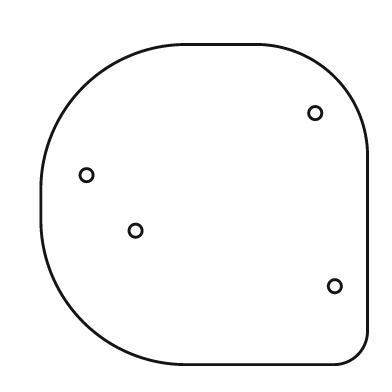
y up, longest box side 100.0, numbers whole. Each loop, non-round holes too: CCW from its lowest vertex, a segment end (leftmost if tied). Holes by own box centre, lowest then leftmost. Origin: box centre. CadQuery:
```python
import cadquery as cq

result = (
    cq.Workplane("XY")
    .moveTo(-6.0, -49.0)
    .lineTo(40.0, -49.0)
    .threePointArc((47.0, -46.0), (50.0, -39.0))
    .lineTo(50.0, 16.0)
    .threePointArc((40.0, 39.0), (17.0, 49.0))
    .lineTo(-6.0, 49.0)
    .threePointArc((-37.0, 36.0), (-50.0, 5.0))
    .lineTo(-50.0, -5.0)
    .threePointArc((-37.0, -36.0), (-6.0, -49.0))
    .close()
    .moveTo(40.0, -25.0)
    .circle(2.0)
    .moveTo(-21.0, -8.0)
    .circle(2.0)
    .moveTo(-36.0, 9.0)
    .circle(2.0)
    .moveTo(34.0, 28.0)
    .circle(2.0)
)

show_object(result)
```